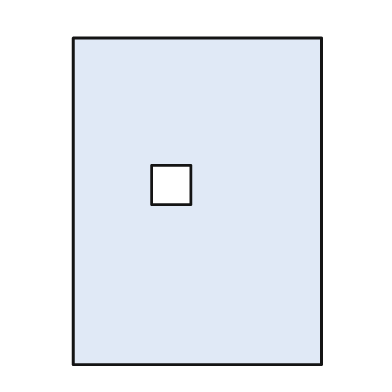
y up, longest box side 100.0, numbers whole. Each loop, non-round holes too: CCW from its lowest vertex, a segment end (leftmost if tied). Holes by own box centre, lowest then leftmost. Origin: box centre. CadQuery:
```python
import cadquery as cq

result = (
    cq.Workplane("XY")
    .moveTo(-38.0, -50.0)
    .lineTo(38.0, -50.0)
    .lineTo(38.0, 50.0)
    .lineTo(-38.0, 50.0)
    .close()
    .moveTo(-14.0, -1.0)
    .lineTo(-2.0, -1.0)
    .lineTo(-2.0, 11.0)
    .lineTo(-14.0, 11.0)
    .close()
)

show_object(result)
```